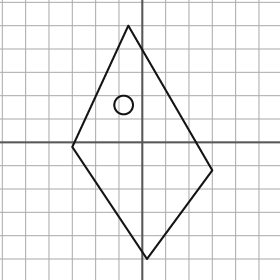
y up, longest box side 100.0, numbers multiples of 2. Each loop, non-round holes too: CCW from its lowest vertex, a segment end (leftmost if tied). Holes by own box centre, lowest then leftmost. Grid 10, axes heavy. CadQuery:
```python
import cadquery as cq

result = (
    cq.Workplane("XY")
    .moveTo(2.0, -50.0)
    .lineTo(30.0, -12.0)
    .lineTo(-6.0, 50.0)
    .lineTo(-30.0, -2.0)
    .close()
    .moveTo(-8.0, 16.0)
    .circle(4.0)
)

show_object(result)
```